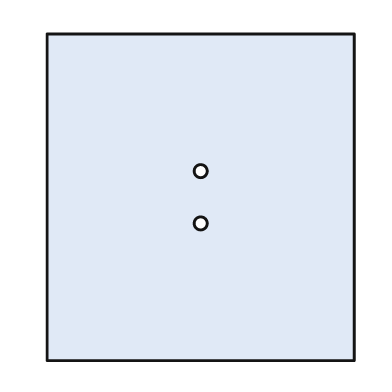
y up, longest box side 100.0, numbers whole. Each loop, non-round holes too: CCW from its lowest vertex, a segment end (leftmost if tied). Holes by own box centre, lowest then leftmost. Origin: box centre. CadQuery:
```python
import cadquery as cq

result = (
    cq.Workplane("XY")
    .moveTo(-47.0, -50.0)
    .lineTo(47.0, -50.0)
    .lineTo(47.0, 50.0)
    .lineTo(-47.0, 50.0)
    .close()
    .moveTo(0.0, -8.0)
    .circle(2.0)
    .moveTo(0.0, 8.0)
    .circle(2.0)
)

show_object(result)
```